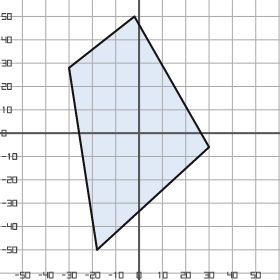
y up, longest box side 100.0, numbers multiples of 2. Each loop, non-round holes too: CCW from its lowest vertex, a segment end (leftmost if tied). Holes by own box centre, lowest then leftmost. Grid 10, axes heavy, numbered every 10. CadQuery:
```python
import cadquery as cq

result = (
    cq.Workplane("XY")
    .moveTo(-18.0, -50.0)
    .lineTo(30.0, -6.0)
    .lineTo(-2.0, 50.0)
    .lineTo(-30.0, 28.0)
    .close()
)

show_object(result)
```